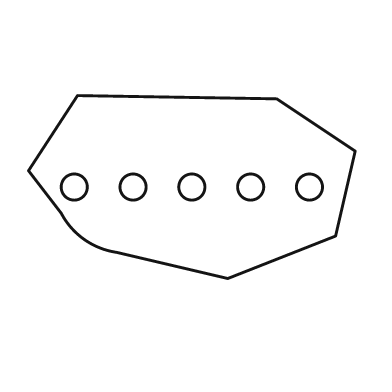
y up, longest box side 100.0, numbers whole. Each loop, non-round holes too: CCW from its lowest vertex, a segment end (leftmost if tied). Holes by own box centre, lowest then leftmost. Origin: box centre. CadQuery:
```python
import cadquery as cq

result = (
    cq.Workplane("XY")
    .moveTo(11.0, -28.0)
    .lineTo(44.0, -15.0)
    .lineTo(50.0, 11.0)
    .lineTo(26.0, 27.0)
    .lineTo(-35.0, 28.0)
    .lineTo(-50.0, 5.0)
    .lineTo(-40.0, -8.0)
    .threePointArc((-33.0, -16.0), (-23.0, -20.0))
    .close()
    .moveTo(-36.0, 0.0)
    .circle(4.0)
    .moveTo(-18.0, 0.0)
    .circle(4.0)
    .moveTo(0.0, 0.0)
    .circle(4.0)
    .moveTo(18.0, 0.0)
    .circle(4.0)
    .moveTo(36.0, 0.0)
    .circle(4.0)
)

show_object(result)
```